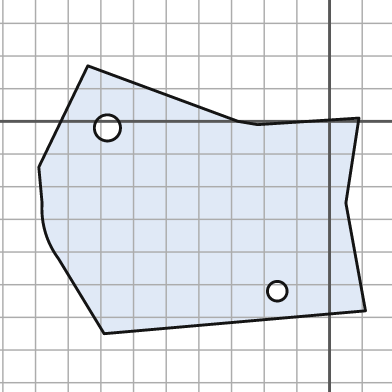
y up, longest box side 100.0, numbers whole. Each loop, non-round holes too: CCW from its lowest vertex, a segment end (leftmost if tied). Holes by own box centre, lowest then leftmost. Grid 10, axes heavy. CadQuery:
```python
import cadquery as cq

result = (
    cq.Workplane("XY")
    .moveTo(-69.0, -65.0)
    .lineTo(11.0, -58.0)
    .lineTo(5.0, -25.0)
    .lineTo(9.0, 1.0)
    .lineTo(-22.0, -1.0)
    .lineTo(-28.0, 0.0)
    .lineTo(-74.0, 17.0)
    .lineTo(-89.0, -14.0)
    .lineTo(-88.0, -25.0)
    .threePointArc((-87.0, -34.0), (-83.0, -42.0))
    .close()
    .moveTo(-16.0, -52.0)
    .circle(3.0)
    .moveTo(-68.0, -2.0)
    .circle(4.0)
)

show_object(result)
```